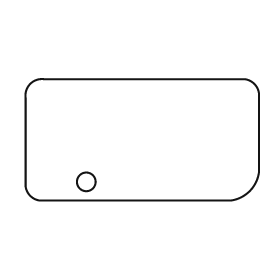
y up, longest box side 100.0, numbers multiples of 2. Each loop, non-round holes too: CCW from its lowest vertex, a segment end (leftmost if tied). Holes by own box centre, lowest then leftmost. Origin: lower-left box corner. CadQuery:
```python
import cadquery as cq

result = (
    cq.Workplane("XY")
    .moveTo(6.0, 0.0)
    .lineTo(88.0, 0.0)
    .threePointArc((96.0, 4.0), (100.0, 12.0))
    .lineTo(100.0, 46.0)
    .threePointArc((98.0, 50.0), (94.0, 52.0))
    .lineTo(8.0, 52.0)
    .threePointArc((2.0, 50.0), (0.0, 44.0))
    .lineTo(0.0, 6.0)
    .threePointArc((2.0, 2.0), (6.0, 0.0))
    .close()
    .moveTo(26.0, 8.0)
    .circle(4.0)
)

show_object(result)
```